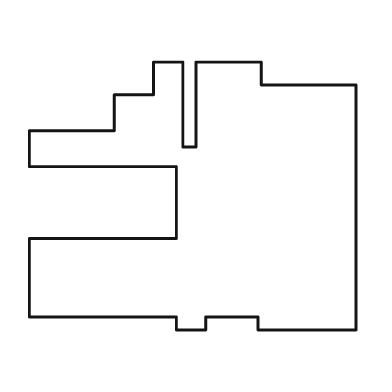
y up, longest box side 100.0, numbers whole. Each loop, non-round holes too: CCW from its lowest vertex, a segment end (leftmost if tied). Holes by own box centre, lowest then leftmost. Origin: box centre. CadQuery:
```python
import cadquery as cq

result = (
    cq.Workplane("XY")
    .moveTo(-5.0, -41.0)
    .lineTo(4.0, -41.0)
    .lineTo(4.0, -37.0)
    .lineTo(20.0, -37.0)
    .lineTo(20.0, -41.0)
    .lineTo(50.0, -41.0)
    .lineTo(50.0, 34.0)
    .lineTo(21.0, 34.0)
    .lineTo(21.0, 41.0)
    .lineTo(1.0, 41.0)
    .lineTo(1.0, 15.0)
    .lineTo(-3.0, 15.0)
    .lineTo(-3.0, 41.0)
    .lineTo(-12.0, 41.0)
    .lineTo(-12.0, 31.0)
    .lineTo(-24.0, 31.0)
    .lineTo(-24.0, 20.0)
    .lineTo(-50.0, 20.0)
    .lineTo(-50.0, 9.0)
    .lineTo(-5.0, 9.0)
    .lineTo(-5.0, -13.0)
    .lineTo(-50.0, -13.0)
    .lineTo(-50.0, -37.0)
    .lineTo(-5.0, -37.0)
    .close()
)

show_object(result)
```